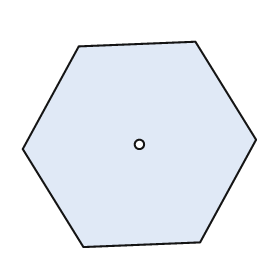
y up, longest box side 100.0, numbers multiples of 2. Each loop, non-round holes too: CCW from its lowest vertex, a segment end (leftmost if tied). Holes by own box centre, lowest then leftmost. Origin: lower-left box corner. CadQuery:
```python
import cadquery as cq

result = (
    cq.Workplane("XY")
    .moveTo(26.0, 0.0)
    .lineTo(76.0, 2.0)
    .lineTo(100.0, 46.0)
    .lineTo(74.0, 88.0)
    .lineTo(24.0, 86.0)
    .lineTo(0.0, 42.0)
    .close()
    .moveTo(50.0, 44.0)
    .circle(2.0)
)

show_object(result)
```